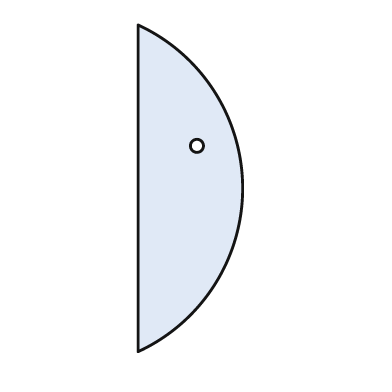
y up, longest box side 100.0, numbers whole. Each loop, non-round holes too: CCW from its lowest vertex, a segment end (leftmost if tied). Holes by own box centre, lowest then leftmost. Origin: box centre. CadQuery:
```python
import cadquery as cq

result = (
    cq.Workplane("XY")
    .moveTo(-16.0, -50.0)
    .threePointArc((16.0, 0.0), (-16.0, 50.0))
    .close()
    .moveTo(2.0, 13.0)
    .circle(2.0)
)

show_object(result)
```